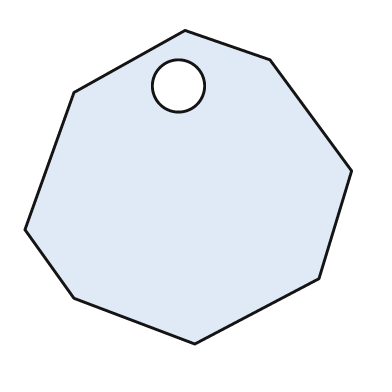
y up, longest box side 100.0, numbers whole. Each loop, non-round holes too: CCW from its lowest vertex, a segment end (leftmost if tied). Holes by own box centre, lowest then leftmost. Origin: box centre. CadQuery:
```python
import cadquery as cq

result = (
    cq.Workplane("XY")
    .moveTo(2.0, -48.0)
    .lineTo(40.0, -28.0)
    .lineTo(50.0, 5.0)
    .lineTo(25.0, 39.0)
    .lineTo(-1.0, 48.0)
    .lineTo(-35.0, 29.0)
    .lineTo(-50.0, -13.0)
    .lineTo(-35.0, -34.0)
    .close()
    .moveTo(-3.0, 31.0)
    .circle(8.0)
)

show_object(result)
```